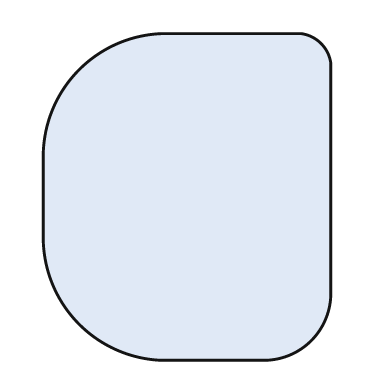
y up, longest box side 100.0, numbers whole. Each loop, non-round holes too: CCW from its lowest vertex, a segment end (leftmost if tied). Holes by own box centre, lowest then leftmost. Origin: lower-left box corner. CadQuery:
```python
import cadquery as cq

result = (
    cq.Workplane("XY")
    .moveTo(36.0, 0.0)
    .lineTo(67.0, 0.0)
    .threePointArc((82.0, 6.0), (88.0, 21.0))
    .lineTo(88.0, 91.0)
    .threePointArc((85.0, 97.0), (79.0, 100.0))
    .lineTo(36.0, 100.0)
    .threePointArc((11.0, 89.0), (0.0, 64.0))
    .lineTo(0.0, 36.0)
    .threePointArc((11.0, 11.0), (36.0, 0.0))
    .close()
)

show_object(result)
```